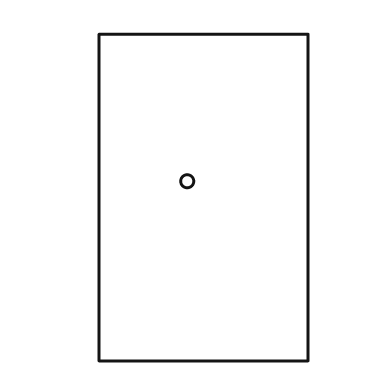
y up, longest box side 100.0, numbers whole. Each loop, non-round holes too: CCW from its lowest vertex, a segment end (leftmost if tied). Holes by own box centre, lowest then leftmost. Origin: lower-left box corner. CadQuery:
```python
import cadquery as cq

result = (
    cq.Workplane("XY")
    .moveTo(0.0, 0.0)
    .lineTo(64.0, 0.0)
    .lineTo(64.0, 100.0)
    .lineTo(0.0, 100.0)
    .close()
    .moveTo(27.0, 55.0)
    .circle(2.0)
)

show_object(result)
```